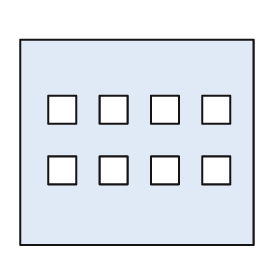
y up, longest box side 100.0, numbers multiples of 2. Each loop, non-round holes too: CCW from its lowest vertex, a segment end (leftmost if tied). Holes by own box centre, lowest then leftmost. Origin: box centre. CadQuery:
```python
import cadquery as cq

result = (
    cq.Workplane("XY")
    .moveTo(-50.0, -44.0)
    .lineTo(50.0, -44.0)
    .lineTo(50.0, 44.0)
    .lineTo(-50.0, 44.0)
    .close()
    .moveTo(-38.0, -18.0)
    .lineTo(-26.0, -18.0)
    .lineTo(-26.0, -6.0)
    .lineTo(-38.0, -6.0)
    .close()
    .moveTo(-16.0, -18.0)
    .lineTo(-4.0, -18.0)
    .lineTo(-4.0, -6.0)
    .lineTo(-16.0, -6.0)
    .close()
    .moveTo(6.0, -18.0)
    .lineTo(18.0, -18.0)
    .lineTo(18.0, -6.0)
    .lineTo(6.0, -6.0)
    .close()
    .moveTo(28.0, -18.0)
    .lineTo(40.0, -18.0)
    .lineTo(40.0, -6.0)
    .lineTo(28.0, -6.0)
    .close()
    .moveTo(-38.0, 8.0)
    .lineTo(-26.0, 8.0)
    .lineTo(-26.0, 20.0)
    .lineTo(-38.0, 20.0)
    .close()
    .moveTo(-16.0, 8.0)
    .lineTo(-4.0, 8.0)
    .lineTo(-4.0, 20.0)
    .lineTo(-16.0, 20.0)
    .close()
    .moveTo(6.0, 8.0)
    .lineTo(18.0, 8.0)
    .lineTo(18.0, 20.0)
    .lineTo(6.0, 20.0)
    .close()
    .moveTo(28.0, 8.0)
    .lineTo(40.0, 8.0)
    .lineTo(40.0, 20.0)
    .lineTo(28.0, 20.0)
    .close()
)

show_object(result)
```